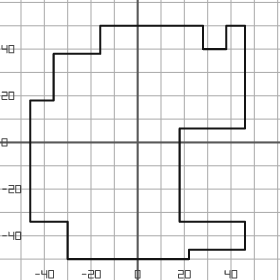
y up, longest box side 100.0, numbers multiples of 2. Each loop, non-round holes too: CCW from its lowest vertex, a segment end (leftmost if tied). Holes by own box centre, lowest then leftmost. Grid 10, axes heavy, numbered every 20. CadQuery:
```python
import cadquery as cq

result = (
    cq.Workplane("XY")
    .moveTo(-30.0, -50.0)
    .lineTo(22.0, -50.0)
    .lineTo(22.0, -46.0)
    .lineTo(46.0, -46.0)
    .lineTo(46.0, -34.0)
    .lineTo(18.0, -34.0)
    .lineTo(18.0, 6.0)
    .lineTo(46.0, 6.0)
    .lineTo(46.0, 50.0)
    .lineTo(38.0, 50.0)
    .lineTo(38.0, 40.0)
    .lineTo(28.0, 40.0)
    .lineTo(28.0, 50.0)
    .lineTo(-16.0, 50.0)
    .lineTo(-16.0, 38.0)
    .lineTo(-36.0, 38.0)
    .lineTo(-36.0, 18.0)
    .lineTo(-46.0, 18.0)
    .lineTo(-46.0, -34.0)
    .lineTo(-30.0, -34.0)
    .close()
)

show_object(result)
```